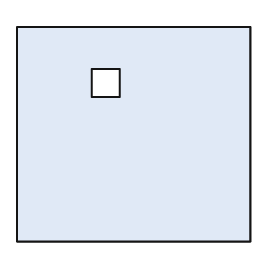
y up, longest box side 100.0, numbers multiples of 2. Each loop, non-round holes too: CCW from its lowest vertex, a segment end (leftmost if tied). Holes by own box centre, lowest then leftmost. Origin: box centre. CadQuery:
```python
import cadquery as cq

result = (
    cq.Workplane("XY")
    .moveTo(-50.0, -46.0)
    .lineTo(50.0, -46.0)
    .lineTo(50.0, 46.0)
    .lineTo(-50.0, 46.0)
    .close()
    .moveTo(-18.0, 16.0)
    .lineTo(-6.0, 16.0)
    .lineTo(-6.0, 28.0)
    .lineTo(-18.0, 28.0)
    .close()
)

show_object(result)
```